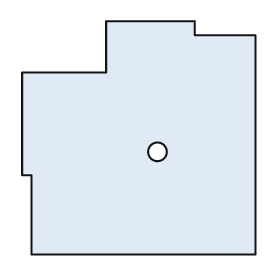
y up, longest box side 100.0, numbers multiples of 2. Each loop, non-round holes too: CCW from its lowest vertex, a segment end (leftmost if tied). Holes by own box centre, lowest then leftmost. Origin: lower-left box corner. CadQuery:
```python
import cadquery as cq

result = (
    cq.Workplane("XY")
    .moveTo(4.0, 0.0)
    .lineTo(100.0, 0.0)
    .lineTo(100.0, 94.0)
    .lineTo(74.0, 94.0)
    .lineTo(74.0, 100.0)
    .lineTo(36.0, 100.0)
    .lineTo(36.0, 78.0)
    .lineTo(0.0, 78.0)
    .lineTo(0.0, 34.0)
    .lineTo(4.0, 34.0)
    .close()
    .moveTo(58.0, 44.0)
    .circle(4.0)
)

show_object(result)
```